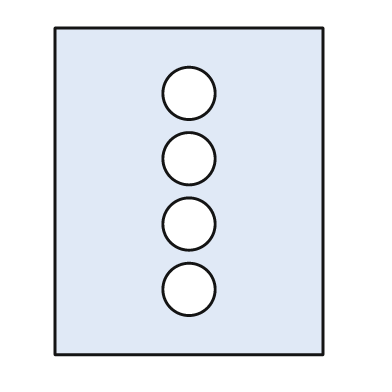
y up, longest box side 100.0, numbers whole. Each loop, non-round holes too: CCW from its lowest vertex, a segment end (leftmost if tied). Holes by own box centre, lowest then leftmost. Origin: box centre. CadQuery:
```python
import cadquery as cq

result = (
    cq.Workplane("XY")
    .moveTo(-41.0, -50.0)
    .lineTo(41.0, -50.0)
    .lineTo(41.0, 50.0)
    .lineTo(-41.0, 50.0)
    .close()
    .moveTo(0.0, -30.0)
    .circle(8.0)
    .moveTo(0.0, -10.0)
    .circle(8.0)
    .moveTo(0.0, 10.0)
    .circle(8.0)
    .moveTo(0.0, 30.0)
    .circle(8.0)
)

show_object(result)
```